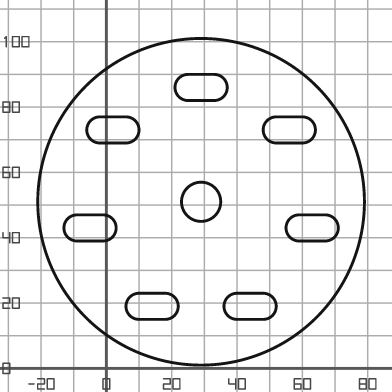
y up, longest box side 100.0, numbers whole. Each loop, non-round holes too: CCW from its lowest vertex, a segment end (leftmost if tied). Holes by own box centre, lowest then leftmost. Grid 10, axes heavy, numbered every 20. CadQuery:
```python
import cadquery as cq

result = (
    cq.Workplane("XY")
    .moveTo(29.0, 51.0)
    .circle(50.0)
    .moveTo(10.0, 15.0)
    .lineTo(18.0, 15.0)
    .threePointArc((22.0, 19.0), (18.0, 23.0))
    .lineTo(10.0, 23.0)
    .threePointArc((6.0, 19.0), (10.0, 15.0))
    .close()
    .moveTo(40.0, 15.0)
    .lineTo(48.0, 15.0)
    .threePointArc((52.0, 19.0), (48.0, 23.0))
    .lineTo(40.0, 23.0)
    .threePointArc((36.0, 19.0), (40.0, 15.0))
    .close()
    .moveTo(-9.0, 39.0)
    .lineTo(-1.0, 39.0)
    .threePointArc((3.0, 43.0), (-1.0, 47.0))
    .lineTo(-9.0, 47.0)
    .threePointArc((-13.0, 43.0), (-9.0, 39.0))
    .close()
    .moveTo(59.0, 39.0)
    .lineTo(67.0, 39.0)
    .threePointArc((71.0, 43.0), (67.0, 47.0))
    .lineTo(59.0, 47.0)
    .threePointArc((55.0, 43.0), (59.0, 39.0))
    .close()
    .moveTo(29.0, 51.0)
    .circle(6.0)
    .moveTo(-2.0, 69.0)
    .lineTo(6.0, 69.0)
    .threePointArc((10.0, 73.0), (6.0, 77.0))
    .lineTo(-2.0, 77.0)
    .threePointArc((-6.0, 73.0), (-2.0, 69.0))
    .close()
    .moveTo(52.0, 69.0)
    .lineTo(60.0, 69.0)
    .threePointArc((64.0, 73.0), (60.0, 77.0))
    .lineTo(52.0, 77.0)
    .threePointArc((48.0, 73.0), (52.0, 69.0))
    .close()
    .moveTo(25.0, 82.0)
    .lineTo(33.0, 82.0)
    .threePointArc((37.0, 86.0), (33.0, 90.0))
    .lineTo(25.0, 90.0)
    .threePointArc((21.0, 86.0), (25.0, 82.0))
    .close()
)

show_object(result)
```